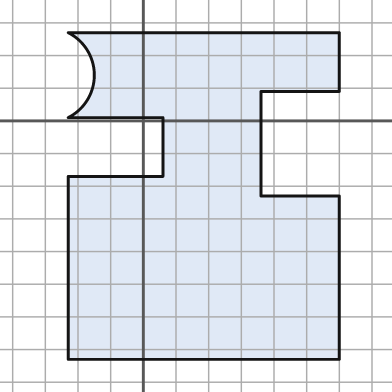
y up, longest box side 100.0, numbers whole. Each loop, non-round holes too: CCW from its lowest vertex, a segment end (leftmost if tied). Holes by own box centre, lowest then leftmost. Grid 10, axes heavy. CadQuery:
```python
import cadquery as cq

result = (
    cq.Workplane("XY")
    .moveTo(-23.0, -73.0)
    .lineTo(60.0, -73.0)
    .lineTo(60.0, -23.0)
    .lineTo(36.0, -23.0)
    .lineTo(36.0, 9.0)
    .lineTo(60.0, 9.0)
    .lineTo(60.0, 27.0)
    .lineTo(-23.0, 27.0)
    .threePointArc((-15.0, 14.0), (-23.0, 1.0))
    .lineTo(6.0, 1.0)
    .lineTo(6.0, -17.0)
    .lineTo(-23.0, -17.0)
    .close()
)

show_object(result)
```